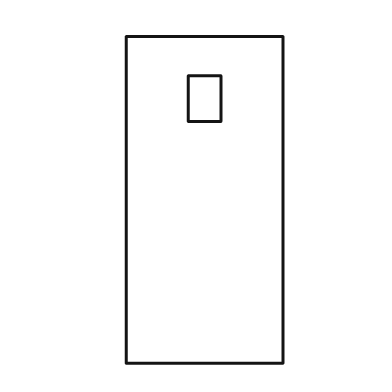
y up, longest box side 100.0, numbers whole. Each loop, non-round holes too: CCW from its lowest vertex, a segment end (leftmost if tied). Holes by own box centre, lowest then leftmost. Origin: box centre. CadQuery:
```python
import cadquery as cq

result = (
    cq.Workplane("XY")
    .moveTo(-24.0, -50.0)
    .lineTo(24.0, -50.0)
    .lineTo(24.0, 50.0)
    .lineTo(-24.0, 50.0)
    .close()
    .moveTo(-5.0, 24.0)
    .lineTo(5.0, 24.0)
    .lineTo(5.0, 38.0)
    .lineTo(-5.0, 38.0)
    .close()
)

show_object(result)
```